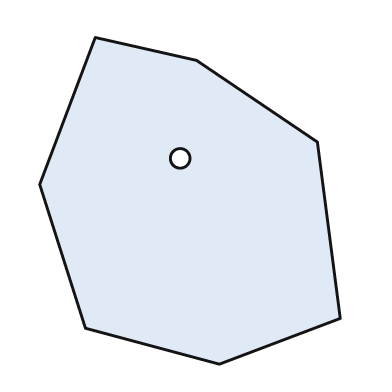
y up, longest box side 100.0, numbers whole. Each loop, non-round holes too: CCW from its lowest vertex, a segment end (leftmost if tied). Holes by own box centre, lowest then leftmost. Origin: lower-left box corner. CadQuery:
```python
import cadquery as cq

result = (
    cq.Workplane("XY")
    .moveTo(55.0, 0.0)
    .lineTo(92.0, 14.0)
    .lineTo(85.0, 68.0)
    .lineTo(48.0, 93.0)
    .lineTo(17.0, 100.0)
    .lineTo(0.0, 55.0)
    .lineTo(14.0, 11.0)
    .close()
    .moveTo(43.0, 63.0)
    .circle(3.0)
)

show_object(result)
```